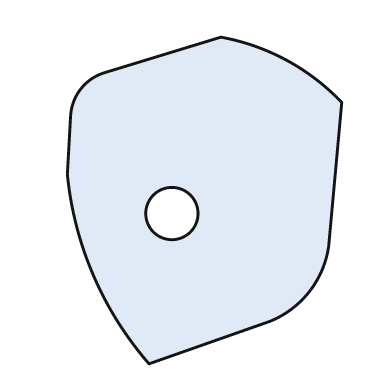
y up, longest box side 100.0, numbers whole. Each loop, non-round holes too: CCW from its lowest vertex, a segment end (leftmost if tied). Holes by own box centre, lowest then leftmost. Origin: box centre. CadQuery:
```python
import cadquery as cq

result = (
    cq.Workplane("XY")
    .moveTo(-17.0, -50.0)
    .lineTo(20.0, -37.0)
    .threePointArc((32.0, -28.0), (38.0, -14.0))
    .lineTo(42.0, 30.0)
    .threePointArc((25.0, 43.0), (5.0, 50.0))
    .lineTo(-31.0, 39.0)
    .threePointArc((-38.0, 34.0), (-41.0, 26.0))
    .lineTo(-42.0, 8.0)
    .threePointArc((-34.0, -23.0), (-17.0, -50.0))
    .close()
    .moveTo(-10.0, -4.0)
    .circle(8.0)
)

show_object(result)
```